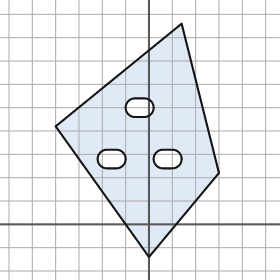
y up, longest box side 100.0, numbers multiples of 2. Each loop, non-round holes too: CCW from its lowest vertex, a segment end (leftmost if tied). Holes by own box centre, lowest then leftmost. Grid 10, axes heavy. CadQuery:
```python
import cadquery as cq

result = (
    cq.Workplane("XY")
    .moveTo(0.0, -14.0)
    .lineTo(30.0, 22.0)
    .lineTo(14.0, 86.0)
    .lineTo(-40.0, 42.0)
    .close()
    .moveTo(-18.0, 24.0)
    .lineTo(-14.0, 24.0)
    .threePointArc((-10.0, 28.0), (-14.0, 32.0))
    .lineTo(-18.0, 32.0)
    .threePointArc((-22.0, 28.0), (-18.0, 24.0))
    .close()
    .moveTo(6.0, 24.0)
    .lineTo(10.0, 24.0)
    .threePointArc((14.0, 28.0), (10.0, 32.0))
    .lineTo(6.0, 32.0)
    .threePointArc((2.0, 28.0), (6.0, 24.0))
    .close()
    .moveTo(-6.0, 46.0)
    .lineTo(-2.0, 46.0)
    .threePointArc((2.0, 50.0), (-2.0, 54.0))
    .lineTo(-6.0, 54.0)
    .threePointArc((-10.0, 50.0), (-6.0, 46.0))
    .close()
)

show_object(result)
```